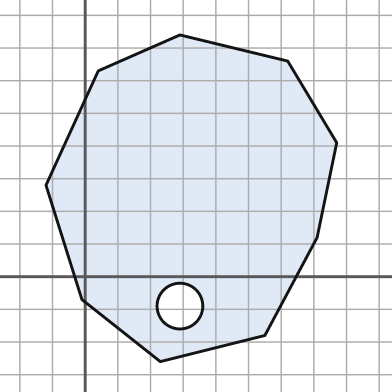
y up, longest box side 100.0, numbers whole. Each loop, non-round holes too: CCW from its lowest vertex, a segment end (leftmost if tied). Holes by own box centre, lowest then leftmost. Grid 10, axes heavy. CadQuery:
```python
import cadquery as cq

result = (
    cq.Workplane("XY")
    .moveTo(23.0, -26.0)
    .lineTo(55.0, -18.0)
    .lineTo(71.0, 12.0)
    .lineTo(77.0, 41.0)
    .lineTo(62.0, 66.0)
    .lineTo(29.0, 74.0)
    .lineTo(4.0, 63.0)
    .lineTo(-12.0, 28.0)
    .lineTo(-1.0, -7.0)
    .close()
    .moveTo(29.0, -9.0)
    .circle(7.0)
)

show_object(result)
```